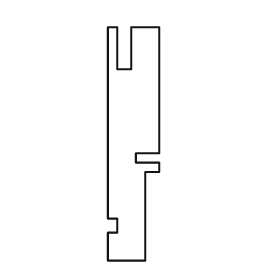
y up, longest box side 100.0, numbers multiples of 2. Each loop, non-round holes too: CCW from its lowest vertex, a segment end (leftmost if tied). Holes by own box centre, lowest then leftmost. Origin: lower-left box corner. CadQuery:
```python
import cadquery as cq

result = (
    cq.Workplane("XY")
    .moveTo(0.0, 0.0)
    .lineTo(16.0, 0.0)
    .lineTo(16.0, 38.0)
    .lineTo(22.0, 38.0)
    .lineTo(22.0, 42.0)
    .lineTo(12.0, 42.0)
    .lineTo(12.0, 46.0)
    .lineTo(22.0, 46.0)
    .lineTo(22.0, 100.0)
    .lineTo(10.0, 100.0)
    .lineTo(10.0, 82.0)
    .lineTo(4.0, 82.0)
    .lineTo(4.0, 100.0)
    .lineTo(0.0, 100.0)
    .lineTo(0.0, 18.0)
    .lineTo(4.0, 18.0)
    .lineTo(4.0, 12.0)
    .lineTo(0.0, 12.0)
    .close()
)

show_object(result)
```